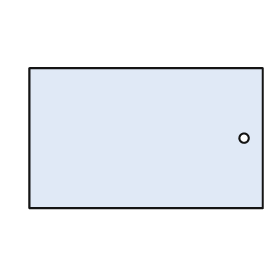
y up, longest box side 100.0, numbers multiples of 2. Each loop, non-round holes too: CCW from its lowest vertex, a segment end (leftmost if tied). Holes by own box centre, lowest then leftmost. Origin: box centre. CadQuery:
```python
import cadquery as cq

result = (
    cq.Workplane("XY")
    .moveTo(-50.0, -30.0)
    .lineTo(50.0, -30.0)
    .lineTo(50.0, 30.0)
    .lineTo(-50.0, 30.0)
    .close()
    .moveTo(42.0, 0.0)
    .circle(2.0)
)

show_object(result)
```